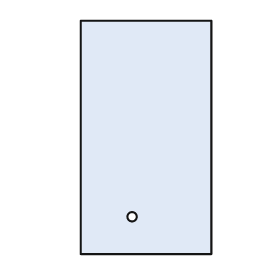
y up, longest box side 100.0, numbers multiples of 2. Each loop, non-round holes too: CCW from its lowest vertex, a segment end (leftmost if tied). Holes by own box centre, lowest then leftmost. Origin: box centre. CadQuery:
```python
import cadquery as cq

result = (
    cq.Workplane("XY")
    .moveTo(-28.0, -50.0)
    .lineTo(28.0, -50.0)
    .lineTo(28.0, 50.0)
    .lineTo(-28.0, 50.0)
    .close()
    .moveTo(-6.0, -34.0)
    .circle(2.0)
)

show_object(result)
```